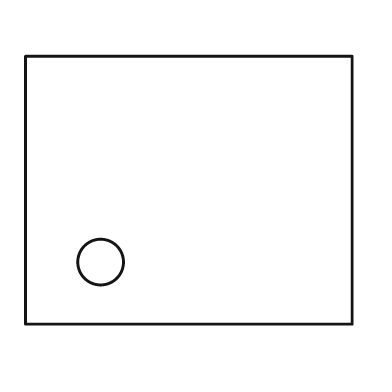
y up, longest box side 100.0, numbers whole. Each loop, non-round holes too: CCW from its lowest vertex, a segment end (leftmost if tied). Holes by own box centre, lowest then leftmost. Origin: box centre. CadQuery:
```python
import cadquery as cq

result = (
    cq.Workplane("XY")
    .moveTo(-50.0, -41.0)
    .lineTo(50.0, -41.0)
    .lineTo(50.0, 41.0)
    .lineTo(-50.0, 41.0)
    .close()
    .moveTo(-27.0, -22.0)
    .circle(7.0)
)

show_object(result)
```